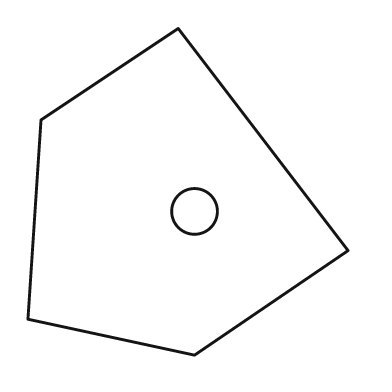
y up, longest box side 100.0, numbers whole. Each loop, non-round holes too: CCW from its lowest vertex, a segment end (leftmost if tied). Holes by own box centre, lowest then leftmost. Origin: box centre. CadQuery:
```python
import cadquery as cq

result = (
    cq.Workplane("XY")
    .moveTo(2.0, -50.0)
    .lineTo(49.0, -18.0)
    .lineTo(-3.0, 50.0)
    .lineTo(-45.0, 22.0)
    .lineTo(-49.0, -39.0)
    .close()
    .moveTo(2.0, -6.0)
    .circle(7.0)
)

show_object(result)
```